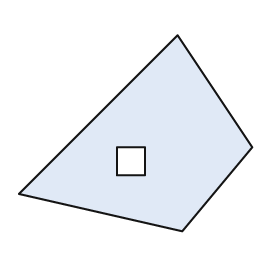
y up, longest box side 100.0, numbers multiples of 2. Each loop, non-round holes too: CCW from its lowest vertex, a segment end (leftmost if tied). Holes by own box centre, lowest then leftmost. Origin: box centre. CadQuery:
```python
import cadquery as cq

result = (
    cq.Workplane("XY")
    .moveTo(20.0, -42.0)
    .lineTo(50.0, -6.0)
    .lineTo(18.0, 42.0)
    .lineTo(-50.0, -26.0)
    .close()
    .moveTo(-8.0, -18.0)
    .lineTo(4.0, -18.0)
    .lineTo(4.0, -6.0)
    .lineTo(-8.0, -6.0)
    .close()
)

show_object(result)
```